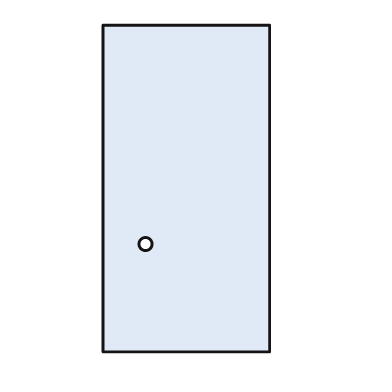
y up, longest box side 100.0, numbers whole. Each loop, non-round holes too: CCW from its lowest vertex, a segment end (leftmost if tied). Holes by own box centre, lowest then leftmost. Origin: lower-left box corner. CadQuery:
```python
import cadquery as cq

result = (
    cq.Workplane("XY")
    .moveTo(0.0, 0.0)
    .lineTo(51.0, 0.0)
    .lineTo(51.0, 100.0)
    .lineTo(0.0, 100.0)
    .close()
    .moveTo(13.0, 33.0)
    .circle(2.0)
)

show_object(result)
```